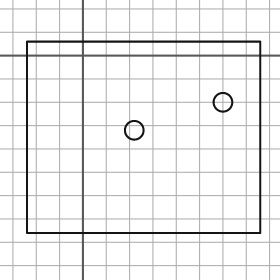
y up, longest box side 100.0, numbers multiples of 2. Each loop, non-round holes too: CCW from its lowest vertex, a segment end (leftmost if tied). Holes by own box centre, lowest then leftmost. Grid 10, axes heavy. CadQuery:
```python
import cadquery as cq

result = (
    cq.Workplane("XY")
    .moveTo(-24.0, -76.0)
    .lineTo(76.0, -76.0)
    .lineTo(76.0, 6.0)
    .lineTo(-24.0, 6.0)
    .close()
    .moveTo(22.0, -32.0)
    .circle(4.0)
    .moveTo(60.0, -20.0)
    .circle(4.0)
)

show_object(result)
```